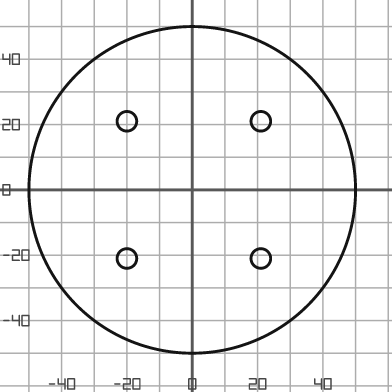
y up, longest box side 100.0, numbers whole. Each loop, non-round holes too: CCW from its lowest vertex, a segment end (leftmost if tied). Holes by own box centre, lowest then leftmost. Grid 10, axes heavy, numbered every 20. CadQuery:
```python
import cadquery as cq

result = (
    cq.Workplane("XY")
    .moveTo(0.0, 0.0)
    .circle(50.0)
    .moveTo(-20.0, -21.0)
    .circle(3.0)
    .moveTo(21.0, -21.0)
    .circle(3.0)
    .moveTo(-20.0, 21.0)
    .circle(3.0)
    .moveTo(21.0, 21.0)
    .circle(3.0)
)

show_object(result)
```